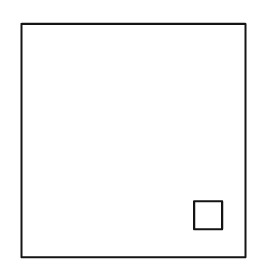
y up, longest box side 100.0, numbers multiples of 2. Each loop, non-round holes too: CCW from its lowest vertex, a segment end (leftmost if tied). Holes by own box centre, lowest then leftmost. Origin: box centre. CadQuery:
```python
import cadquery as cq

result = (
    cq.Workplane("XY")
    .moveTo(-48.0, -50.0)
    .lineTo(48.0, -50.0)
    .lineTo(48.0, 50.0)
    .lineTo(-48.0, 50.0)
    .close()
    .moveTo(26.0, -38.0)
    .lineTo(38.0, -38.0)
    .lineTo(38.0, -26.0)
    .lineTo(26.0, -26.0)
    .close()
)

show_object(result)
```